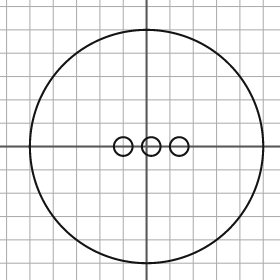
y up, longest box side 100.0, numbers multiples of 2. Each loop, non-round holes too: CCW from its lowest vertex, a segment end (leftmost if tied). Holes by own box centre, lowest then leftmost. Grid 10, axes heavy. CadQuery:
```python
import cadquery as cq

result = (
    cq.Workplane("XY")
    .moveTo(0.0, 0.0)
    .circle(50.0)
    .moveTo(-10.0, 0.0)
    .circle(4.0)
    .moveTo(2.0, 0.0)
    .circle(4.0)
    .moveTo(14.0, 0.0)
    .circle(4.0)
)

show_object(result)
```